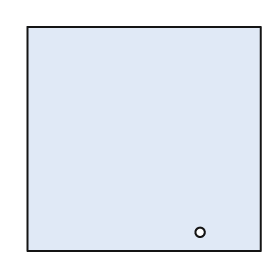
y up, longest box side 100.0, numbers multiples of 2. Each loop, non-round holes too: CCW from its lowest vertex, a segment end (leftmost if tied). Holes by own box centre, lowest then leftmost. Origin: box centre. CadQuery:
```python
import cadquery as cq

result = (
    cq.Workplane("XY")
    .moveTo(-50.0, -48.0)
    .lineTo(50.0, -48.0)
    .lineTo(50.0, 48.0)
    .lineTo(-50.0, 48.0)
    .close()
    .moveTo(24.0, -40.0)
    .circle(2.0)
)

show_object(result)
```